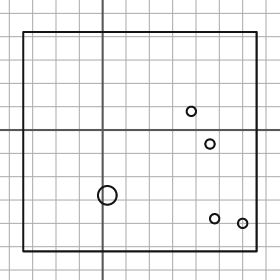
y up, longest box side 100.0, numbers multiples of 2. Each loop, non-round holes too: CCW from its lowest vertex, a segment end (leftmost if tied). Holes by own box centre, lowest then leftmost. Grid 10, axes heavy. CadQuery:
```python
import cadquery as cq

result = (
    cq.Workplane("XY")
    .moveTo(-34.0, -52.0)
    .lineTo(66.0, -52.0)
    .lineTo(66.0, 42.0)
    .lineTo(-34.0, 42.0)
    .close()
    .moveTo(60.0, -40.0)
    .circle(2.0)
    .moveTo(48.0, -38.0)
    .circle(2.0)
    .moveTo(2.0, -28.0)
    .circle(4.0)
    .moveTo(46.0, -6.0)
    .circle(2.0)
    .moveTo(38.0, 8.0)
    .circle(2.0)
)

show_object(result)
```